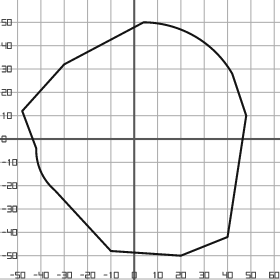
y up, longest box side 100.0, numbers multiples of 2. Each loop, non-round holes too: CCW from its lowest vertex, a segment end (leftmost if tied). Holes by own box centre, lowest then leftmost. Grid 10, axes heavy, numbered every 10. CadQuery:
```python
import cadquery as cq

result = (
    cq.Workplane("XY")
    .moveTo(20.0, -50.0)
    .lineTo(40.0, -42.0)
    .lineTo(48.0, 10.0)
    .lineTo(42.0, 28.0)
    .threePointArc((26.0, 44.0), (4.0, 50.0))
    .lineTo(-30.0, 32.0)
    .lineTo(-48.0, 12.0)
    .lineTo(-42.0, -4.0)
    .threePointArc((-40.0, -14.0), (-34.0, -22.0))
    .lineTo(-10.0, -48.0)
    .close()
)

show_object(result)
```